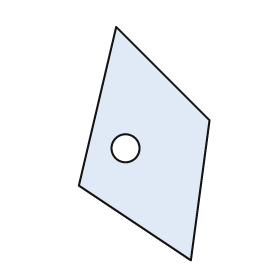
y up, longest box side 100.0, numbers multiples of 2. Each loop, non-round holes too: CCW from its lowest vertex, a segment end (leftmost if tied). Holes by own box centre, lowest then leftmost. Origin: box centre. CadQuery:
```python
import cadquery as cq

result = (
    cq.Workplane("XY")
    .moveTo(20.0, -50.0)
    .lineTo(28.0, 10.0)
    .lineTo(-12.0, 50.0)
    .lineTo(-28.0, -18.0)
    .close()
    .moveTo(-8.0, -2.0)
    .circle(6.0)
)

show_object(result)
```